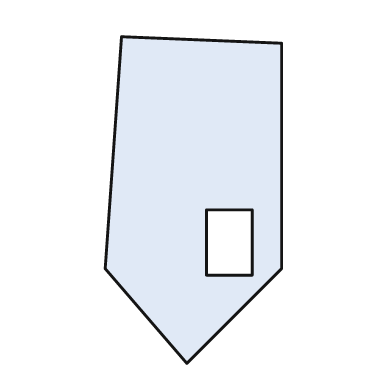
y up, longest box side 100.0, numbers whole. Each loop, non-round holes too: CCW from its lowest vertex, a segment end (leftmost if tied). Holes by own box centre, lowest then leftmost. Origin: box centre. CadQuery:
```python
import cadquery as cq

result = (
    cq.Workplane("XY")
    .moveTo(-2.0, -50.0)
    .lineTo(27.0, -21.0)
    .lineTo(27.0, 48.0)
    .lineTo(-22.0, 50.0)
    .lineTo(-27.0, -21.0)
    .close()
    .moveTo(4.0, -23.0)
    .lineTo(18.0, -23.0)
    .lineTo(18.0, -3.0)
    .lineTo(4.0, -3.0)
    .close()
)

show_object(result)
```